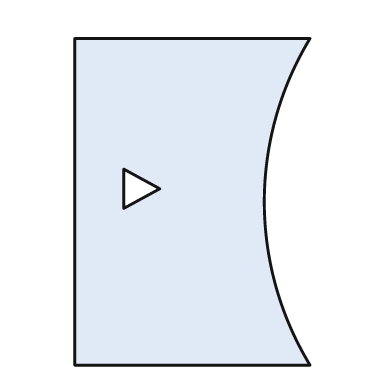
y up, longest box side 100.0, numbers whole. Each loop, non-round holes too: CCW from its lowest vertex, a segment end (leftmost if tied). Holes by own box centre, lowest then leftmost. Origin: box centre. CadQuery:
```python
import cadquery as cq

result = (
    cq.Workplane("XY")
    .moveTo(-36.0, -50.0)
    .lineTo(36.0, -50.0)
    .threePointArc((22.0, 0.0), (36.0, 50.0))
    .lineTo(-36.0, 50.0)
    .close()
    .moveTo(-21.0, -2.0)
    .lineTo(-10.0, 4.0)
    .lineTo(-21.0, 10.0)
    .close()
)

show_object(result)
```